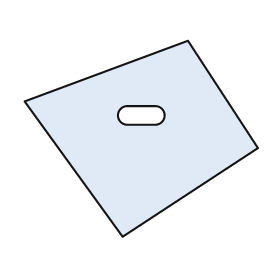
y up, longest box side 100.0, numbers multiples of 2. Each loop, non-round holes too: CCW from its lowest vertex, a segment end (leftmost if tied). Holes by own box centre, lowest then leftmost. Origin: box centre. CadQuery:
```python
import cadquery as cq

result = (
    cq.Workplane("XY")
    .moveTo(-8.0, -42.0)
    .lineTo(50.0, -4.0)
    .lineTo(20.0, 42.0)
    .lineTo(-50.0, 16.0)
    .close()
    .moveTo(-6.0, 6.0)
    .lineTo(6.0, 6.0)
    .threePointArc((10.0, 10.0), (6.0, 14.0))
    .lineTo(-6.0, 14.0)
    .threePointArc((-10.0, 10.0), (-6.0, 6.0))
    .close()
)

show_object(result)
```